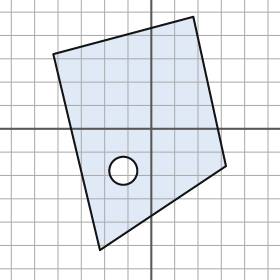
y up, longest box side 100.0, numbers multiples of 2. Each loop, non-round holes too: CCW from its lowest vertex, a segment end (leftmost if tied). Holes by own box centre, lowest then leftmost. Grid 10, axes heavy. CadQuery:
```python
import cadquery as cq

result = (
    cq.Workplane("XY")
    .moveTo(-22.0, -52.0)
    .lineTo(32.0, -16.0)
    .lineTo(18.0, 48.0)
    .lineTo(-42.0, 32.0)
    .close()
    .moveTo(-12.0, -18.0)
    .circle(6.0)
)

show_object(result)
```